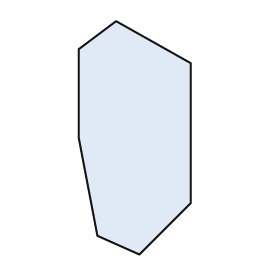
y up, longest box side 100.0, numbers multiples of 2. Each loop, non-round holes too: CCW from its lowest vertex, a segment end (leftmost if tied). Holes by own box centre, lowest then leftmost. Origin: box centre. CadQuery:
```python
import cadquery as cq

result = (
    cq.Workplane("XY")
    .moveTo(2.0, -50.0)
    .lineTo(24.0, -28.0)
    .lineTo(24.0, 32.0)
    .lineTo(-8.0, 50.0)
    .lineTo(-24.0, 38.0)
    .lineTo(-24.0, 0.0)
    .lineTo(-16.0, -42.0)
    .close()
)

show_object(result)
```